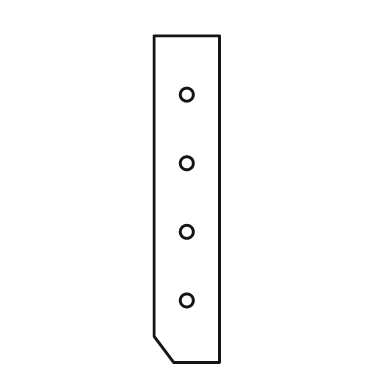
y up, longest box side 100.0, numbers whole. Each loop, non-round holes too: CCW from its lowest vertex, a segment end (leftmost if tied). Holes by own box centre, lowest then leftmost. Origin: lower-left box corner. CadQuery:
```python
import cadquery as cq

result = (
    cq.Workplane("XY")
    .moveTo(6.0, 0.0)
    .lineTo(20.0, 0.0)
    .lineTo(20.0, 100.0)
    .lineTo(0.0, 100.0)
    .lineTo(0.0, 8.0)
    .close()
    .moveTo(10.0, 19.0)
    .circle(2.0)
    .moveTo(10.0, 40.0)
    .circle(2.0)
    .moveTo(10.0, 61.0)
    .circle(2.0)
    .moveTo(10.0, 82.0)
    .circle(2.0)
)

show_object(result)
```